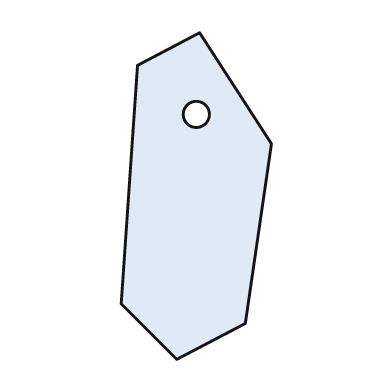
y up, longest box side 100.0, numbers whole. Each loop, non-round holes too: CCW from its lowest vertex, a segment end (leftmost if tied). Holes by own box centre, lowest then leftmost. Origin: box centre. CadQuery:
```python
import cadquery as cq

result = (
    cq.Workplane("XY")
    .moveTo(-6.0, -50.0)
    .lineTo(15.0, -39.0)
    .lineTo(23.0, 16.0)
    .lineTo(1.0, 50.0)
    .lineTo(-18.0, 40.0)
    .lineTo(-23.0, -33.0)
    .close()
    .moveTo(0.0, 25.0)
    .circle(4.0)
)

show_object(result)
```